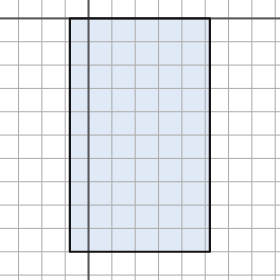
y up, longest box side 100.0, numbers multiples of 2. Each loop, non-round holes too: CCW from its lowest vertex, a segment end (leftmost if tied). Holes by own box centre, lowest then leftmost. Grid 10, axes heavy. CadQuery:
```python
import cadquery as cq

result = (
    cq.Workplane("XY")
    .moveTo(-8.0, -100.0)
    .lineTo(52.0, -100.0)
    .lineTo(52.0, 0.0)
    .lineTo(-8.0, 0.0)
    .close()
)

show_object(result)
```